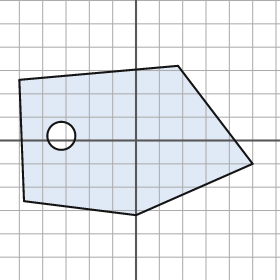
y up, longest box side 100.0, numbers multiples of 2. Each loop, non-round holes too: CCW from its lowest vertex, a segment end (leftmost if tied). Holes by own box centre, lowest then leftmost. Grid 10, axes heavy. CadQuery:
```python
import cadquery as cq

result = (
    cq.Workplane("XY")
    .moveTo(0.0, -32.0)
    .lineTo(50.0, -10.0)
    .lineTo(18.0, 32.0)
    .lineTo(-50.0, 26.0)
    .lineTo(-48.0, -26.0)
    .close()
    .moveTo(-32.0, 2.0)
    .circle(6.0)
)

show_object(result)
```